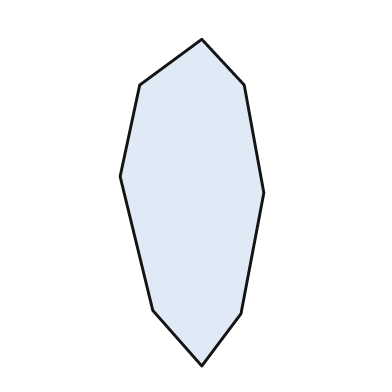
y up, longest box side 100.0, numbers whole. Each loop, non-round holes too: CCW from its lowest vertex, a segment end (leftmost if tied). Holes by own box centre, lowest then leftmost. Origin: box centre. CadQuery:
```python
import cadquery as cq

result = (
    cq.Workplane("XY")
    .moveTo(3.0, -50.0)
    .lineTo(15.0, -34.0)
    .lineTo(22.0, 3.0)
    .lineTo(16.0, 36.0)
    .lineTo(3.0, 50.0)
    .lineTo(-16.0, 36.0)
    .lineTo(-22.0, 8.0)
    .lineTo(-12.0, -33.0)
    .close()
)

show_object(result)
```